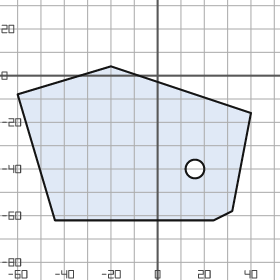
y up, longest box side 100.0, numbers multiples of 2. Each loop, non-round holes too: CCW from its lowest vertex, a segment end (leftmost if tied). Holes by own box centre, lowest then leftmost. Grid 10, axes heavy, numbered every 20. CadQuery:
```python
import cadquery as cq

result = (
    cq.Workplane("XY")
    .moveTo(-44.0, -62.0)
    .lineTo(24.0, -62.0)
    .lineTo(32.0, -58.0)
    .lineTo(40.0, -16.0)
    .lineTo(-20.0, 4.0)
    .lineTo(-60.0, -8.0)
    .close()
    .moveTo(16.0, -40.0)
    .circle(4.0)
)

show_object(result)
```